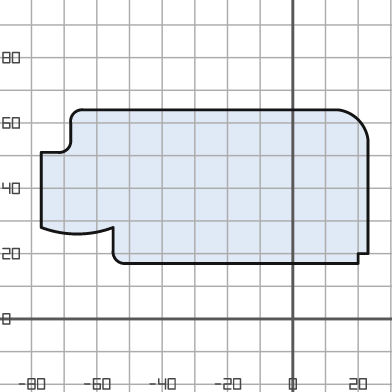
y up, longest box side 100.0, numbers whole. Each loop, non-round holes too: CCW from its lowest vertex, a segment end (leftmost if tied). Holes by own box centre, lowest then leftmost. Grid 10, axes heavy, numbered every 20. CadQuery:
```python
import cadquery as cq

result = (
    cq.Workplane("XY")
    .moveTo(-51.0, 17.0)
    .lineTo(20.0, 17.0)
    .lineTo(20.0, 20.0)
    .lineTo(23.0, 20.0)
    .lineTo(23.0, 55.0)
    .threePointArc((20.0, 61.0), (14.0, 64.0))
    .lineTo(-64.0, 64.0)
    .threePointArc((-67.0, 63.0), (-68.0, 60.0))
    .lineTo(-68.0, 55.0)
    .threePointArc((-69.0, 52.0), (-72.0, 51.0))
    .lineTo(-77.0, 51.0)
    .lineTo(-77.0, 28.0)
    .threePointArc((-66.0, 26.0), (-55.0, 28.0))
    .lineTo(-55.0, 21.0)
    .threePointArc((-54.0, 18.0), (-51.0, 17.0))
    .close()
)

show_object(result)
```